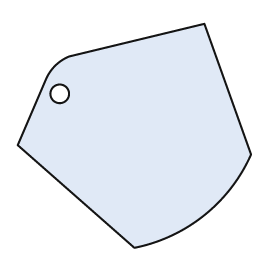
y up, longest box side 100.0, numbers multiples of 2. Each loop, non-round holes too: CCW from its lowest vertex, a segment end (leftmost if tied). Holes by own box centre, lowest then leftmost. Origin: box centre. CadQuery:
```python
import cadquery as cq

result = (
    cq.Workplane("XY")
    .moveTo(0.0, -48.0)
    .threePointArc((30.0, -34.0), (50.0, -8.0))
    .lineTo(30.0, 48.0)
    .lineTo(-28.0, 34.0)
    .threePointArc((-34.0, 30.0), (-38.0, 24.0))
    .lineTo(-50.0, -4.0)
    .close()
    .moveTo(-32.0, 18.0)
    .circle(4.0)
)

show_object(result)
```